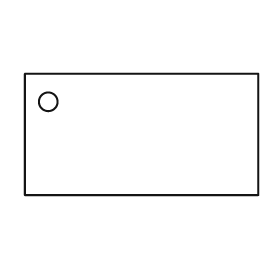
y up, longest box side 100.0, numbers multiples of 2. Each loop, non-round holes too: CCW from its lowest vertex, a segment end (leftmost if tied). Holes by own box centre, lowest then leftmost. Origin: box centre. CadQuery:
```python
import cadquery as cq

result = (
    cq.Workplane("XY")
    .moveTo(-50.0, -26.0)
    .lineTo(50.0, -26.0)
    .lineTo(50.0, 26.0)
    .lineTo(-50.0, 26.0)
    .close()
    .moveTo(-40.0, 14.0)
    .circle(4.0)
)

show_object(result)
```